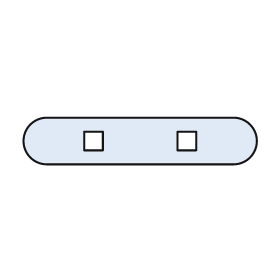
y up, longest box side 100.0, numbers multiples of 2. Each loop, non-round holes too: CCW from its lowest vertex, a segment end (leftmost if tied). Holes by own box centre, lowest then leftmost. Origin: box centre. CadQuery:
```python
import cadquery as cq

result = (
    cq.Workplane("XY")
    .moveTo(-40.0, -10.0)
    .lineTo(40.0, -10.0)
    .threePointArc((50.0, 0.0), (40.0, 10.0))
    .lineTo(-40.0, 10.0)
    .threePointArc((-50.0, 0.0), (-40.0, -10.0))
    .close()
    .moveTo(-24.0, -4.0)
    .lineTo(-16.0, -4.0)
    .lineTo(-16.0, 4.0)
    .lineTo(-24.0, 4.0)
    .close()
    .moveTo(16.0, -4.0)
    .lineTo(24.0, -4.0)
    .lineTo(24.0, 4.0)
    .lineTo(16.0, 4.0)
    .close()
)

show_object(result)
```